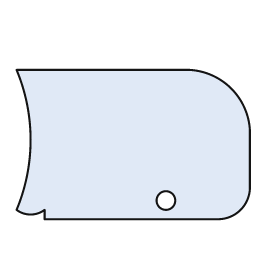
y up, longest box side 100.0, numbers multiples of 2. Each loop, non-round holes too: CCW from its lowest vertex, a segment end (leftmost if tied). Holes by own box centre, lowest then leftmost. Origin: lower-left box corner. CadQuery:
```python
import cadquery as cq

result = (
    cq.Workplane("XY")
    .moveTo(12.0, 0.0)
    .lineTo(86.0, 0.0)
    .threePointArc((96.0, 4.0), (100.0, 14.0))
    .lineTo(100.0, 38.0)
    .threePointArc((92.0, 56.0), (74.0, 64.0))
    .lineTo(0.0, 64.0)
    .threePointArc((6.0, 34.0), (0.0, 4.0))
    .threePointArc((6.0, 2.0), (12.0, 4.0))
    .close()
    .moveTo(64.0, 8.0)
    .circle(4.0)
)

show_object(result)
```